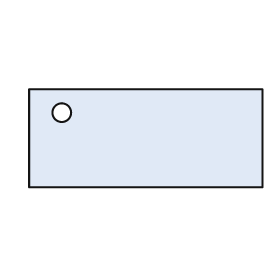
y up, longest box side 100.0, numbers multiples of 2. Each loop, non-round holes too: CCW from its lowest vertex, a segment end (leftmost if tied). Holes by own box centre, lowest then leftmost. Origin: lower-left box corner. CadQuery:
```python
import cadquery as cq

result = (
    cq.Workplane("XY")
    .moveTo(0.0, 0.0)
    .lineTo(100.0, 0.0)
    .lineTo(100.0, 42.0)
    .lineTo(0.0, 42.0)
    .close()
    .moveTo(14.0, 32.0)
    .circle(4.0)
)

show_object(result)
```